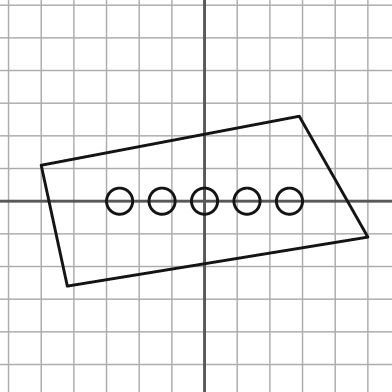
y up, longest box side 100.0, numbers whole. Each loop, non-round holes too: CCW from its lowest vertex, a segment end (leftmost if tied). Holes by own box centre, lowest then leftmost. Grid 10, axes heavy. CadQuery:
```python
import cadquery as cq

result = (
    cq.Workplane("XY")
    .moveTo(-42.0, -26.0)
    .lineTo(50.0, -11.0)
    .lineTo(29.0, 26.0)
    .lineTo(-50.0, 11.0)
    .close()
    .moveTo(-26.0, 0.0)
    .circle(4.0)
    .moveTo(-13.0, 0.0)
    .circle(4.0)
    .moveTo(0.0, 0.0)
    .circle(4.0)
    .moveTo(13.0, 0.0)
    .circle(4.0)
    .moveTo(26.0, 0.0)
    .circle(4.0)
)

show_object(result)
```